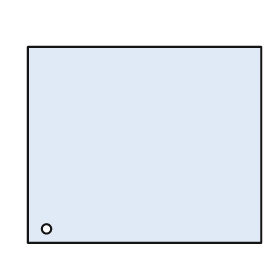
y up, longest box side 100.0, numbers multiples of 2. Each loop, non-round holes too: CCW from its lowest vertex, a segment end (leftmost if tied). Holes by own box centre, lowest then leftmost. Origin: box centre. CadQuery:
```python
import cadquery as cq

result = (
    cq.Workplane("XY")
    .moveTo(-50.0, -42.0)
    .lineTo(50.0, -42.0)
    .lineTo(50.0, 42.0)
    .lineTo(-50.0, 42.0)
    .close()
    .moveTo(-42.0, -36.0)
    .circle(2.0)
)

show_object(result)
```